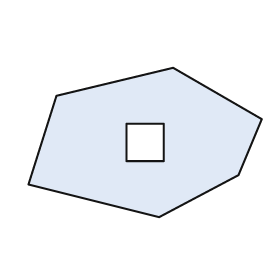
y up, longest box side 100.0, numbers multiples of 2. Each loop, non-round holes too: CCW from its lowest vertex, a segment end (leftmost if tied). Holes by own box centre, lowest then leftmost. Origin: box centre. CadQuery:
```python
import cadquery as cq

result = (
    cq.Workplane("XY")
    .moveTo(6.0, -32.0)
    .lineTo(40.0, -14.0)
    .lineTo(50.0, 10.0)
    .lineTo(12.0, 32.0)
    .lineTo(-38.0, 20.0)
    .lineTo(-50.0, -18.0)
    .close()
    .moveTo(-8.0, -8.0)
    .lineTo(8.0, -8.0)
    .lineTo(8.0, 8.0)
    .lineTo(-8.0, 8.0)
    .close()
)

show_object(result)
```